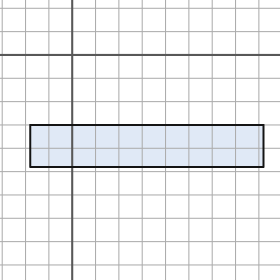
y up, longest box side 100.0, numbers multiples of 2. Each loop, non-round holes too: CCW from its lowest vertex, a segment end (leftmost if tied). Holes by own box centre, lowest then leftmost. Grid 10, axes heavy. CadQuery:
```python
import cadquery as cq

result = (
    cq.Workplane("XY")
    .moveTo(-18.0, -48.0)
    .lineTo(82.0, -48.0)
    .lineTo(82.0, -30.0)
    .lineTo(-18.0, -30.0)
    .close()
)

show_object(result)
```